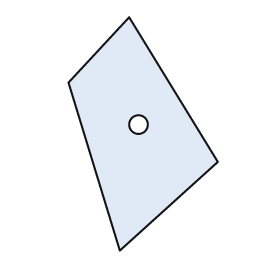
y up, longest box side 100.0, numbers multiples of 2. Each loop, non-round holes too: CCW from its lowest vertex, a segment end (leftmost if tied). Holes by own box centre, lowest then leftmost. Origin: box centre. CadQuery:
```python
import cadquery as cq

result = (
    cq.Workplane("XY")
    .moveTo(-10.0, -50.0)
    .lineTo(32.0, -12.0)
    .lineTo(-6.0, 50.0)
    .lineTo(-32.0, 22.0)
    .close()
    .moveTo(-2.0, 4.0)
    .circle(4.0)
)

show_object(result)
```